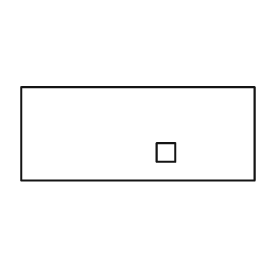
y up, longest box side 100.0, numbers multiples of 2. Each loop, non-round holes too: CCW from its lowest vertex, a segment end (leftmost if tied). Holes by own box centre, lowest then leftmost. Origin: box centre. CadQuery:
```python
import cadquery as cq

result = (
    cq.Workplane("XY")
    .moveTo(-50.0, -20.0)
    .lineTo(50.0, -20.0)
    .lineTo(50.0, 20.0)
    .lineTo(-50.0, 20.0)
    .close()
    .moveTo(8.0, -12.0)
    .lineTo(16.0, -12.0)
    .lineTo(16.0, -4.0)
    .lineTo(8.0, -4.0)
    .close()
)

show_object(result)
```